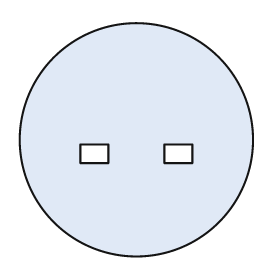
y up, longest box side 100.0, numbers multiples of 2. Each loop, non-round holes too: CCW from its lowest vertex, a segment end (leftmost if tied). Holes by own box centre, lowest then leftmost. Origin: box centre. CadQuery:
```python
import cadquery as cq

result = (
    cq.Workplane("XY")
    .moveTo(0.0, 0.0)
    .circle(50.0)
    .moveTo(-24.0, -10.0)
    .lineTo(-12.0, -10.0)
    .lineTo(-12.0, -2.0)
    .lineTo(-24.0, -2.0)
    .close()
    .moveTo(12.0, -10.0)
    .lineTo(24.0, -10.0)
    .lineTo(24.0, -2.0)
    .lineTo(12.0, -2.0)
    .close()
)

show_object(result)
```